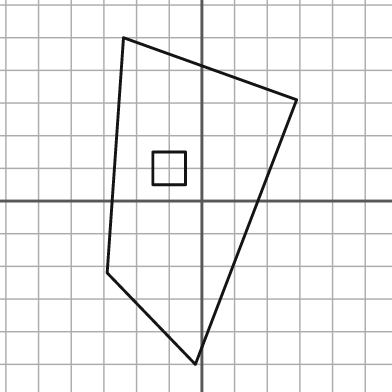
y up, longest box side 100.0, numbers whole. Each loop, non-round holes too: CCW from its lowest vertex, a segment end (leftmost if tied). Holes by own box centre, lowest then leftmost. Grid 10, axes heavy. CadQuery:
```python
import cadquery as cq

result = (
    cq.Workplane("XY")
    .moveTo(-2.0, -50.0)
    .lineTo(29.0, 31.0)
    .lineTo(-24.0, 50.0)
    .lineTo(-29.0, -22.0)
    .close()
    .moveTo(-15.0, 5.0)
    .lineTo(-5.0, 5.0)
    .lineTo(-5.0, 15.0)
    .lineTo(-15.0, 15.0)
    .close()
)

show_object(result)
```